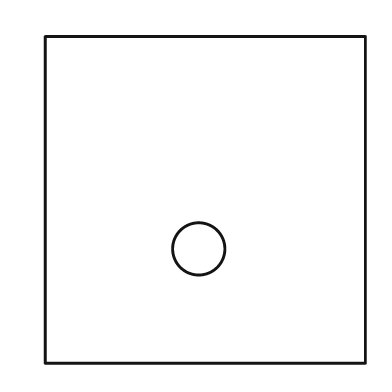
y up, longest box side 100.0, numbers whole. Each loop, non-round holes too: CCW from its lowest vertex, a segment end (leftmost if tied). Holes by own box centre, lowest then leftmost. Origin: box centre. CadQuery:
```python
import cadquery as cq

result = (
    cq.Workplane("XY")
    .moveTo(-49.0, -50.0)
    .lineTo(49.0, -50.0)
    .lineTo(49.0, 50.0)
    .lineTo(-49.0, 50.0)
    .close()
    .moveTo(-2.0, -15.0)
    .circle(8.0)
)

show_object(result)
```